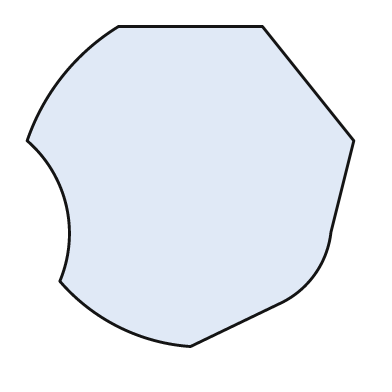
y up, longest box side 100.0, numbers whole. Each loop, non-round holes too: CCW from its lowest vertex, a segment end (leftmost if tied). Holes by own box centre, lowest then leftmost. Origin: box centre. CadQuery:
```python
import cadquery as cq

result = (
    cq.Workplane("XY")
    .moveTo(0.0, -49.0)
    .lineTo(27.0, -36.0)
    .threePointArc((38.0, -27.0), (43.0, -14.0))
    .lineTo(50.0, 14.0)
    .lineTo(22.0, 49.0)
    .lineTo(-22.0, 49.0)
    .threePointArc((-39.0, 34.0), (-50.0, 14.0))
    .threePointArc((-38.0, -6.0), (-40.0, -29.0))
    .threePointArc((-22.0, -43.0), (0.0, -49.0))
    .close()
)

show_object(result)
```